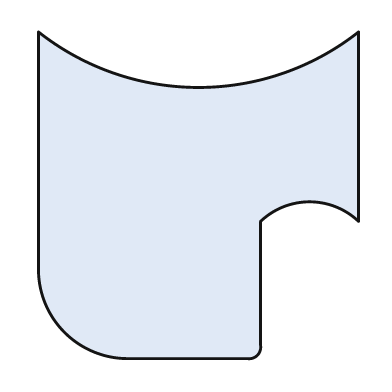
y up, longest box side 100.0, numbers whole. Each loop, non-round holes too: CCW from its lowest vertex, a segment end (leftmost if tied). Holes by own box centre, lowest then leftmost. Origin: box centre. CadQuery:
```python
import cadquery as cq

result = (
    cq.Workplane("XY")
    .moveTo(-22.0, -50.0)
    .lineTo(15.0, -50.0)
    .threePointArc((18.0, -49.0), (19.0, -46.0))
    .lineTo(19.0, -8.0)
    .threePointArc((34.0, -2.0), (49.0, -8.0))
    .lineTo(49.0, 50.0)
    .threePointArc((0.0, 33.0), (-49.0, 50.0))
    .lineTo(-49.0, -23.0)
    .threePointArc((-41.0, -42.0), (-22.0, -50.0))
    .close()
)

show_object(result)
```